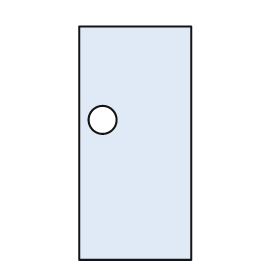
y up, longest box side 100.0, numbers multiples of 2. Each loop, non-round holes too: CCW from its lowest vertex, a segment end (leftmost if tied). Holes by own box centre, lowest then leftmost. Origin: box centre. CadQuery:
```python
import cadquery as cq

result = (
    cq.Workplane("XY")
    .moveTo(-24.0, -50.0)
    .lineTo(24.0, -50.0)
    .lineTo(24.0, 50.0)
    .lineTo(-24.0, 50.0)
    .close()
    .moveTo(-14.0, 10.0)
    .circle(6.0)
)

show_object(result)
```